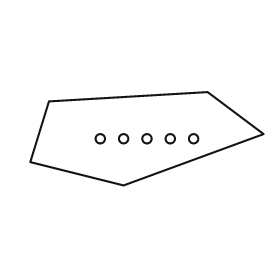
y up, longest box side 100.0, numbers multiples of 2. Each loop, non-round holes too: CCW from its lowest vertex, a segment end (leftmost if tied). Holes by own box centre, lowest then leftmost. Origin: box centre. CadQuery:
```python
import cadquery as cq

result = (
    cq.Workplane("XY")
    .moveTo(-10.0, -20.0)
    .lineTo(50.0, 2.0)
    .lineTo(26.0, 20.0)
    .lineTo(-42.0, 16.0)
    .lineTo(-50.0, -10.0)
    .close()
    .moveTo(-20.0, 0.0)
    .circle(2.0)
    .moveTo(-10.0, 0.0)
    .circle(2.0)
    .moveTo(0.0, 0.0)
    .circle(2.0)
    .moveTo(10.0, 0.0)
    .circle(2.0)
    .moveTo(20.0, 0.0)
    .circle(2.0)
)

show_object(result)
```